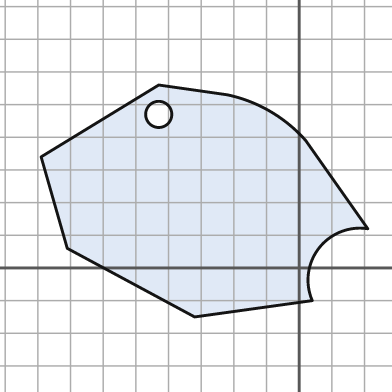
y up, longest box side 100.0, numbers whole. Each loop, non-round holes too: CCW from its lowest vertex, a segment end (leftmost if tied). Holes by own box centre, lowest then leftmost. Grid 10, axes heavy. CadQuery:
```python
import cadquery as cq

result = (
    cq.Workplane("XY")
    .moveTo(-32.0, -15.0)
    .lineTo(4.0, -10.0)
    .threePointArc((6.0, 6.0), (21.0, 12.0))
    .lineTo(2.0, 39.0)
    .threePointArc((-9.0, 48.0), (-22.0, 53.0))
    .lineTo(-43.0, 56.0)
    .lineTo(-79.0, 34.0)
    .lineTo(-71.0, 6.0)
    .close()
    .moveTo(-43.0, 47.0)
    .circle(4.0)
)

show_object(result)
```